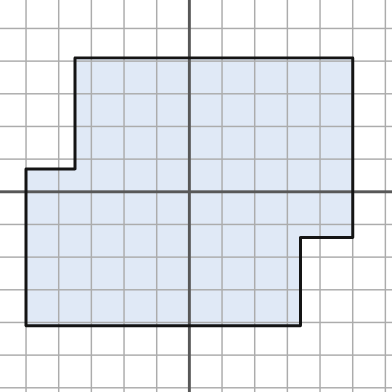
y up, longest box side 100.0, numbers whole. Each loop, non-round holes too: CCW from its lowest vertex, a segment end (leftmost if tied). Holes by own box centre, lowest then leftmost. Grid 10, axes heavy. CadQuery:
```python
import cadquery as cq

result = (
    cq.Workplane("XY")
    .moveTo(-50.0, -41.0)
    .lineTo(34.0, -41.0)
    .lineTo(34.0, -14.0)
    .lineTo(50.0, -14.0)
    .lineTo(50.0, 41.0)
    .lineTo(-35.0, 41.0)
    .lineTo(-35.0, 7.0)
    .lineTo(-50.0, 7.0)
    .close()
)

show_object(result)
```